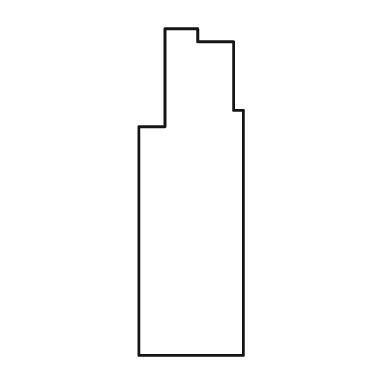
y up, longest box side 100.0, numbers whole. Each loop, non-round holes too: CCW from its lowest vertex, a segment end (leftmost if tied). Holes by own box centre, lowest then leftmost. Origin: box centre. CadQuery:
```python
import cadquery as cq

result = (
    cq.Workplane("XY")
    .moveTo(-16.0, -50.0)
    .lineTo(16.0, -50.0)
    .lineTo(16.0, 25.0)
    .lineTo(13.0, 25.0)
    .lineTo(13.0, 46.0)
    .lineTo(2.0, 46.0)
    .lineTo(2.0, 50.0)
    .lineTo(-8.0, 50.0)
    .lineTo(-8.0, 20.0)
    .lineTo(-16.0, 20.0)
    .close()
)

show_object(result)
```